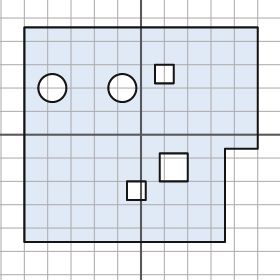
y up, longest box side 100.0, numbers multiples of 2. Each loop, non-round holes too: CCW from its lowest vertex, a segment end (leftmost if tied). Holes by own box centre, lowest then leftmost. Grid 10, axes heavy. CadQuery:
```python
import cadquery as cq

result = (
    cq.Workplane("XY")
    .moveTo(-50.0, -46.0)
    .lineTo(36.0, -46.0)
    .lineTo(36.0, -6.0)
    .lineTo(50.0, -6.0)
    .lineTo(50.0, 46.0)
    .lineTo(-50.0, 46.0)
    .close()
    .moveTo(-6.0, -28.0)
    .lineTo(2.0, -28.0)
    .lineTo(2.0, -20.0)
    .lineTo(-6.0, -20.0)
    .close()
    .moveTo(8.0, -20.0)
    .lineTo(20.0, -20.0)
    .lineTo(20.0, -8.0)
    .lineTo(8.0, -8.0)
    .close()
    .moveTo(-38.0, 20.0)
    .circle(6.0)
    .moveTo(-8.0, 20.0)
    .circle(6.0)
    .moveTo(6.0, 22.0)
    .lineTo(14.0, 22.0)
    .lineTo(14.0, 30.0)
    .lineTo(6.0, 30.0)
    .close()
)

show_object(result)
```